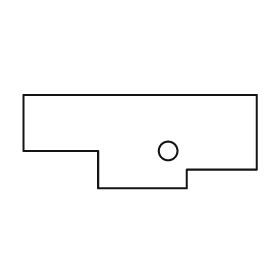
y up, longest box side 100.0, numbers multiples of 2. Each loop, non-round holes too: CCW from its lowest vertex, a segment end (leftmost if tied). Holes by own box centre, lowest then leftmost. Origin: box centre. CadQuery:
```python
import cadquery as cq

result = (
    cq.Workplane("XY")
    .moveTo(-18.0, -20.0)
    .lineTo(20.0, -20.0)
    .lineTo(20.0, -12.0)
    .lineTo(50.0, -12.0)
    .lineTo(50.0, 20.0)
    .lineTo(-50.0, 20.0)
    .lineTo(-50.0, -4.0)
    .lineTo(-18.0, -4.0)
    .close()
    .moveTo(12.0, -4.0)
    .circle(4.0)
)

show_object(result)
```